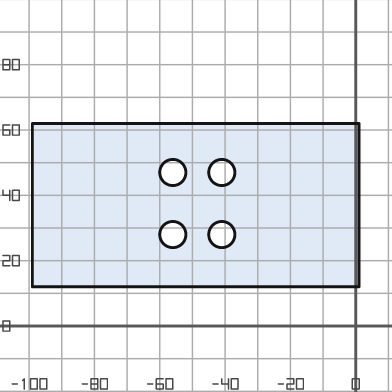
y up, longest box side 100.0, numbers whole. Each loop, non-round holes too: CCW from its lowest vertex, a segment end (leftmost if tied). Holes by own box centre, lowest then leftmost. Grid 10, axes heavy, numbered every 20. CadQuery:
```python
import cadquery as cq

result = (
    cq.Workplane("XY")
    .moveTo(-99.0, 12.0)
    .lineTo(1.0, 12.0)
    .lineTo(1.0, 62.0)
    .lineTo(-99.0, 62.0)
    .close()
    .moveTo(-56.0, 28.0)
    .circle(4.0)
    .moveTo(-41.0, 28.0)
    .circle(4.0)
    .moveTo(-56.0, 47.0)
    .circle(4.0)
    .moveTo(-41.0, 47.0)
    .circle(4.0)
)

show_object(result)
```